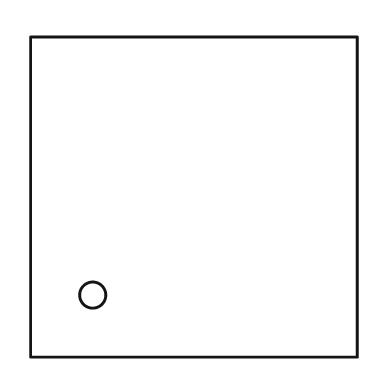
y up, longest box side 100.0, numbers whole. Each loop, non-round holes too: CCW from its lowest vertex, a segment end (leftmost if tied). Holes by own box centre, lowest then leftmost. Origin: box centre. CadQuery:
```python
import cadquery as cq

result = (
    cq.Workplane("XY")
    .moveTo(-50.0, -49.0)
    .lineTo(50.0, -49.0)
    .lineTo(50.0, 49.0)
    .lineTo(-50.0, 49.0)
    .close()
    .moveTo(-31.0, -30.0)
    .circle(4.0)
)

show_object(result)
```